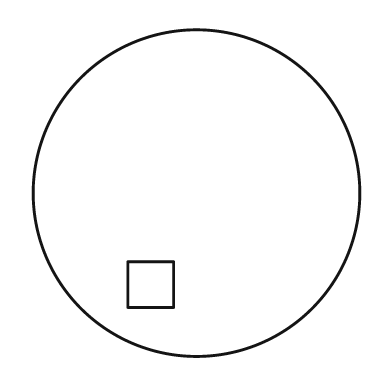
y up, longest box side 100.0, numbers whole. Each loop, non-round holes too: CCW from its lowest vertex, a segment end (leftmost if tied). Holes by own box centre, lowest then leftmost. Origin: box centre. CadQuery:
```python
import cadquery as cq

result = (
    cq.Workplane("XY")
    .moveTo(0.0, 0.0)
    .circle(50.0)
    .moveTo(-21.0, -35.0)
    .lineTo(-7.0, -35.0)
    .lineTo(-7.0, -21.0)
    .lineTo(-21.0, -21.0)
    .close()
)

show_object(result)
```